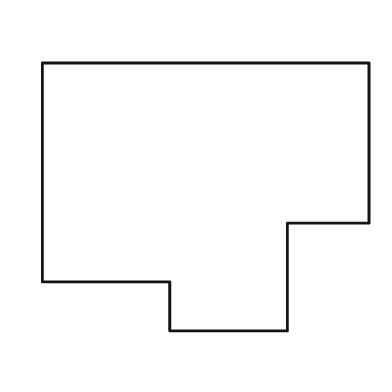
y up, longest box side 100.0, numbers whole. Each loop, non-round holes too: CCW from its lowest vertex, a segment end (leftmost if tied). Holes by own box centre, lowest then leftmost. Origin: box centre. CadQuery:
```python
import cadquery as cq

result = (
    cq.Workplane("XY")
    .moveTo(-11.0, -41.0)
    .lineTo(25.0, -41.0)
    .lineTo(25.0, -8.0)
    .lineTo(50.0, -8.0)
    .lineTo(50.0, 41.0)
    .lineTo(-50.0, 41.0)
    .lineTo(-50.0, -26.0)
    .lineTo(-11.0, -26.0)
    .close()
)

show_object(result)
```